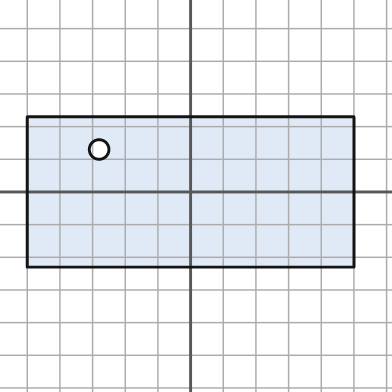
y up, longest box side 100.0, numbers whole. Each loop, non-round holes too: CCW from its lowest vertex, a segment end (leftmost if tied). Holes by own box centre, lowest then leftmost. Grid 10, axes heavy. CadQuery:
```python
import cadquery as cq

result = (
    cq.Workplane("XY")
    .moveTo(-50.0, -23.0)
    .lineTo(50.0, -23.0)
    .lineTo(50.0, 23.0)
    .lineTo(-50.0, 23.0)
    .close()
    .moveTo(-28.0, 13.0)
    .circle(3.0)
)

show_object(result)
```